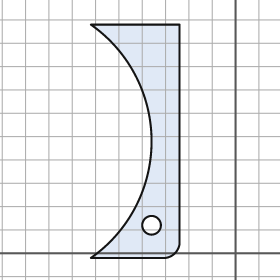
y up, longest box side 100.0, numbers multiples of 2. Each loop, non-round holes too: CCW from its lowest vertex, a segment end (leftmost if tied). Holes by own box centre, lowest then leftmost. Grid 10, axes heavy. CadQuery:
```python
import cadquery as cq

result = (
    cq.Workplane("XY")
    .moveTo(-62.0, -2.0)
    .lineTo(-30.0, -2.0)
    .threePointArc((-26.0, 0.0), (-24.0, 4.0))
    .lineTo(-24.0, 98.0)
    .lineTo(-62.0, 98.0)
    .threePointArc((-36.0, 48.0), (-62.0, -2.0))
    .close()
    .moveTo(-36.0, 12.0)
    .circle(4.0)
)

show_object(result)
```